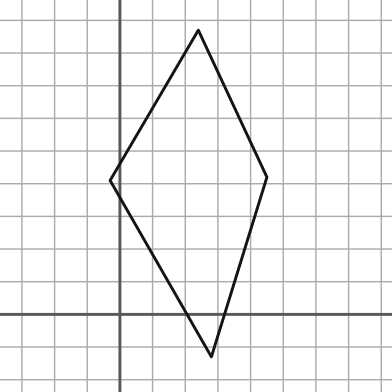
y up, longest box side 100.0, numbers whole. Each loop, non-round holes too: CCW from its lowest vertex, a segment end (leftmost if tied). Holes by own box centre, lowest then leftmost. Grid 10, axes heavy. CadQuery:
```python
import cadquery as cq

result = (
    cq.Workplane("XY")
    .moveTo(28.0, -13.0)
    .lineTo(45.0, 42.0)
    .lineTo(24.0, 87.0)
    .lineTo(-3.0, 41.0)
    .close()
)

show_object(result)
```